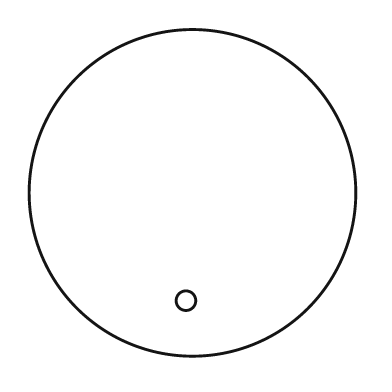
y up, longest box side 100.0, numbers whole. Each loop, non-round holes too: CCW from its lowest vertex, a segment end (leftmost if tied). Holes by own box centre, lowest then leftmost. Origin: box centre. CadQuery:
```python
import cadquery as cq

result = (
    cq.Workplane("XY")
    .moveTo(0.0, 0.0)
    .circle(50.0)
    .moveTo(-2.0, -33.0)
    .circle(3.0)
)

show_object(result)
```